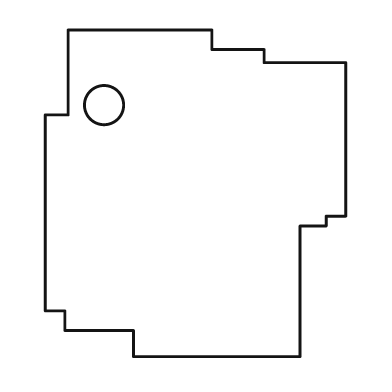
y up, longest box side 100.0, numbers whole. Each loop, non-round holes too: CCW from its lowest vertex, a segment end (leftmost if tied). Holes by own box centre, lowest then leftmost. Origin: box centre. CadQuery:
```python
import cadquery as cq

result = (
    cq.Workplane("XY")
    .moveTo(-19.0, -50.0)
    .lineTo(32.0, -50.0)
    .lineTo(32.0, -10.0)
    .lineTo(40.0, -10.0)
    .lineTo(40.0, -7.0)
    .lineTo(46.0, -7.0)
    .lineTo(46.0, 40.0)
    .lineTo(21.0, 40.0)
    .lineTo(21.0, 44.0)
    .lineTo(5.0, 44.0)
    .lineTo(5.0, 50.0)
    .lineTo(-39.0, 50.0)
    .lineTo(-39.0, 24.0)
    .lineTo(-46.0, 24.0)
    .lineTo(-46.0, -36.0)
    .lineTo(-40.0, -36.0)
    .lineTo(-40.0, -42.0)
    .lineTo(-19.0, -42.0)
    .close()
    .moveTo(-28.0, 27.0)
    .circle(6.0)
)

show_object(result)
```